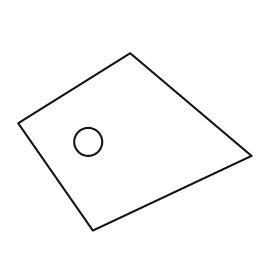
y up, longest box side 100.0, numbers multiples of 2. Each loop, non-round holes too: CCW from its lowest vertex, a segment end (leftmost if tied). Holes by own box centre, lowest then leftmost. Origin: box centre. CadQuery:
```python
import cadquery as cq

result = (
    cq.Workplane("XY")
    .moveTo(-18.0, -38.0)
    .lineTo(50.0, -6.0)
    .lineTo(-2.0, 38.0)
    .lineTo(-50.0, 8.0)
    .close()
    .moveTo(-20.0, 0.0)
    .circle(6.0)
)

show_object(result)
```